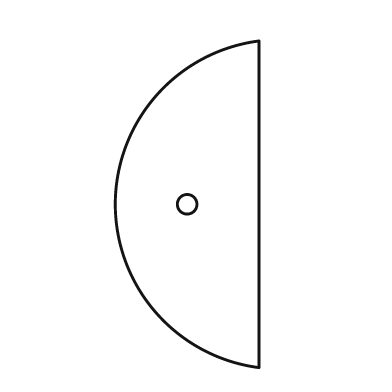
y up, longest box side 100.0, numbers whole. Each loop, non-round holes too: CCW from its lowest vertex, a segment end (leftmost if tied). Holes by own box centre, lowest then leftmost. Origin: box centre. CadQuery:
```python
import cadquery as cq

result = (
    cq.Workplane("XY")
    .moveTo(22.0, -50.0)
    .lineTo(22.0, 50.0)
    .threePointArc((-22.0, 0.0), (22.0, -50.0))
    .close()
    .moveTo(0.0, 0.0)
    .circle(3.0)
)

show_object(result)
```